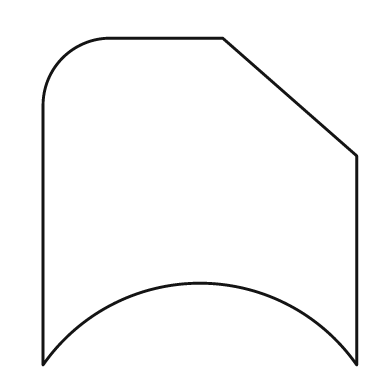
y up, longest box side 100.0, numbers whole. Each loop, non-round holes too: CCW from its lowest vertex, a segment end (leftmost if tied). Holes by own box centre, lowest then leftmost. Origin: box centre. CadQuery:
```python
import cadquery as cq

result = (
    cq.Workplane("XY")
    .moveTo(-48.0, -50.0)
    .threePointArc((0.0, -25.0), (48.0, -50.0))
    .lineTo(48.0, 14.0)
    .lineTo(7.0, 50.0)
    .lineTo(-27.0, 50.0)
    .threePointArc((-42.0, 44.0), (-48.0, 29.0))
    .close()
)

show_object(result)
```